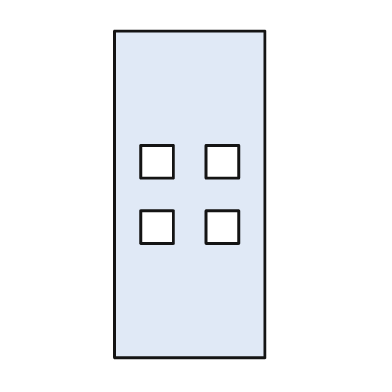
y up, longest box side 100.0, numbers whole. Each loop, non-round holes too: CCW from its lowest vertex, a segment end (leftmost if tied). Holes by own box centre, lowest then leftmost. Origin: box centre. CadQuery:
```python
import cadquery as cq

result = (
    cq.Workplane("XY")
    .moveTo(-23.0, -50.0)
    .lineTo(23.0, -50.0)
    .lineTo(23.0, 50.0)
    .lineTo(-23.0, 50.0)
    .close()
    .moveTo(-15.0, -15.0)
    .lineTo(-5.0, -15.0)
    .lineTo(-5.0, -5.0)
    .lineTo(-15.0, -5.0)
    .close()
    .moveTo(5.0, -15.0)
    .lineTo(15.0, -15.0)
    .lineTo(15.0, -5.0)
    .lineTo(5.0, -5.0)
    .close()
    .moveTo(-15.0, 5.0)
    .lineTo(-5.0, 5.0)
    .lineTo(-5.0, 15.0)
    .lineTo(-15.0, 15.0)
    .close()
    .moveTo(5.0, 5.0)
    .lineTo(15.0, 5.0)
    .lineTo(15.0, 15.0)
    .lineTo(5.0, 15.0)
    .close()
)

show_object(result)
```